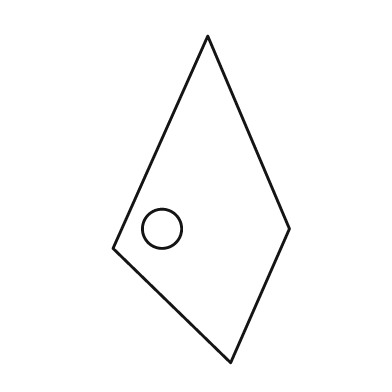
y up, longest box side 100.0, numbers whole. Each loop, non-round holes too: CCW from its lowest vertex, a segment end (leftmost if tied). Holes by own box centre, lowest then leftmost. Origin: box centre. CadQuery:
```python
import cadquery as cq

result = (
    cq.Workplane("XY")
    .moveTo(9.0, -50.0)
    .lineTo(27.0, -9.0)
    .lineTo(2.0, 50.0)
    .lineTo(-27.0, -15.0)
    .close()
    .moveTo(-12.0, -9.0)
    .circle(6.0)
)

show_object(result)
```